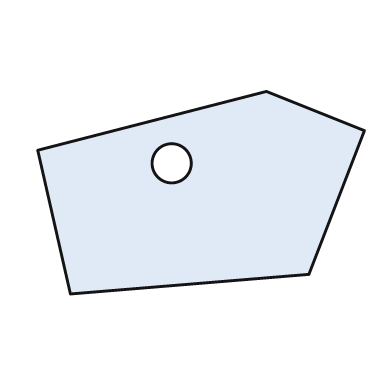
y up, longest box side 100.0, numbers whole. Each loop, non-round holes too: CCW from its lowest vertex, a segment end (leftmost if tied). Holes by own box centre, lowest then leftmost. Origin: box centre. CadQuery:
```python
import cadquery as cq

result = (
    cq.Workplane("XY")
    .moveTo(-40.0, -31.0)
    .lineTo(33.0, -25.0)
    .lineTo(50.0, 19.0)
    .lineTo(20.0, 31.0)
    .lineTo(-50.0, 13.0)
    .close()
    .moveTo(-9.0, 9.0)
    .circle(6.0)
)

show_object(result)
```